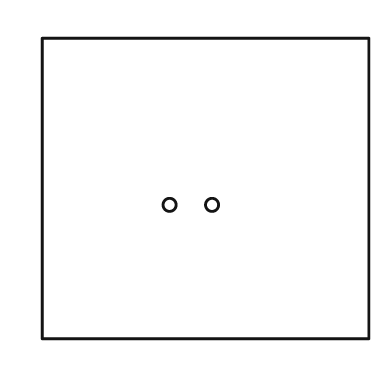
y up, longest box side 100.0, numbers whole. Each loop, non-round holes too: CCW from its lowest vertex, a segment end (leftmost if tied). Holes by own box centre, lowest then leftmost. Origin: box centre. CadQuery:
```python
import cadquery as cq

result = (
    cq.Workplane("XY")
    .moveTo(-50.0, -46.0)
    .lineTo(50.0, -46.0)
    .lineTo(50.0, 46.0)
    .lineTo(-50.0, 46.0)
    .close()
    .moveTo(-11.0, -5.0)
    .circle(2.0)
    .moveTo(2.0, -5.0)
    .circle(2.0)
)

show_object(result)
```